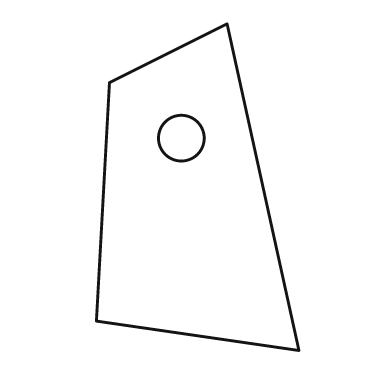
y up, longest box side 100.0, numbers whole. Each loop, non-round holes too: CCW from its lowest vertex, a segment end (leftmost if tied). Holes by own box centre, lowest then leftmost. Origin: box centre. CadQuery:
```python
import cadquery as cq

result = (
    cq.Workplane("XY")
    .moveTo(31.0, -50.0)
    .lineTo(9.0, 50.0)
    .lineTo(-27.0, 32.0)
    .lineTo(-31.0, -41.0)
    .close()
    .moveTo(-5.0, 15.0)
    .circle(7.0)
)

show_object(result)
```